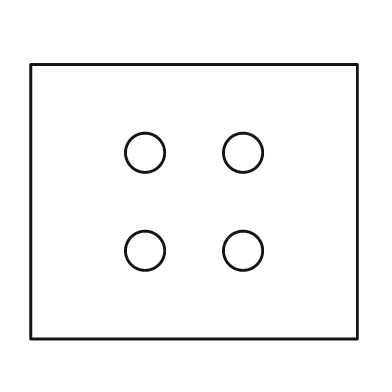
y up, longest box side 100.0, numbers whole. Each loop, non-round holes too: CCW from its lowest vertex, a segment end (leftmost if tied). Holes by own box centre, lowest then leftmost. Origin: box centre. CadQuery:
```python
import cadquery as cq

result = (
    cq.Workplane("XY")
    .moveTo(-50.0, -42.0)
    .lineTo(50.0, -42.0)
    .lineTo(50.0, 42.0)
    .lineTo(-50.0, 42.0)
    .close()
    .moveTo(-15.0, -15.0)
    .circle(6.0)
    .moveTo(15.0, -15.0)
    .circle(6.0)
    .moveTo(-15.0, 15.0)
    .circle(6.0)
    .moveTo(15.0, 15.0)
    .circle(6.0)
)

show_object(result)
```